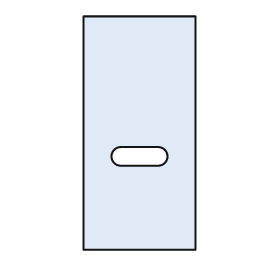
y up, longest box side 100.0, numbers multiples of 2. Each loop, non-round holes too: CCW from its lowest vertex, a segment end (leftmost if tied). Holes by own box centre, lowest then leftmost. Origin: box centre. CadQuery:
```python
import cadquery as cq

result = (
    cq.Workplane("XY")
    .moveTo(-24.0, -50.0)
    .lineTo(24.0, -50.0)
    .lineTo(24.0, 50.0)
    .lineTo(-24.0, 50.0)
    .close()
    .moveTo(-8.0, -14.0)
    .lineTo(8.0, -14.0)
    .threePointArc((12.0, -10.0), (8.0, -6.0))
    .lineTo(-8.0, -6.0)
    .threePointArc((-12.0, -10.0), (-8.0, -14.0))
    .close()
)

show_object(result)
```